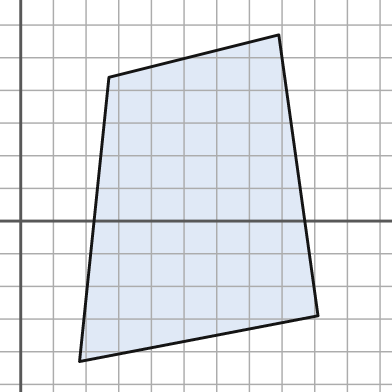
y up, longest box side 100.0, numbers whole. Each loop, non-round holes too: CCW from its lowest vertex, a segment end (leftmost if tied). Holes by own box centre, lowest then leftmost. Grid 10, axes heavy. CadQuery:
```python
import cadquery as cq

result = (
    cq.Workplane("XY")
    .moveTo(18.0, -43.0)
    .lineTo(91.0, -29.0)
    .lineTo(79.0, 57.0)
    .lineTo(27.0, 44.0)
    .close()
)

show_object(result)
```